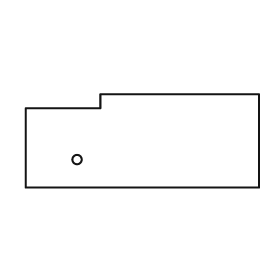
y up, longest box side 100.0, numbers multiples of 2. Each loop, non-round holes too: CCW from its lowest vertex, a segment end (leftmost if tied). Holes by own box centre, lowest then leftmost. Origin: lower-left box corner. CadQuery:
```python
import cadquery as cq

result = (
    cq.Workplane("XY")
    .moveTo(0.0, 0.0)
    .lineTo(100.0, 0.0)
    .lineTo(100.0, 40.0)
    .lineTo(32.0, 40.0)
    .lineTo(32.0, 34.0)
    .lineTo(0.0, 34.0)
    .close()
    .moveTo(22.0, 12.0)
    .circle(2.0)
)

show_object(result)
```